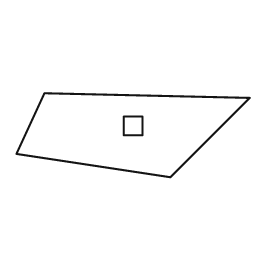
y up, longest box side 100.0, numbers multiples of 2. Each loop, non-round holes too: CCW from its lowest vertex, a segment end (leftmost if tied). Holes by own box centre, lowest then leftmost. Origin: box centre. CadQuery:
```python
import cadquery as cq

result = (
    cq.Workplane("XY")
    .moveTo(16.0, -18.0)
    .lineTo(50.0, 16.0)
    .lineTo(-38.0, 18.0)
    .lineTo(-50.0, -8.0)
    .close()
    .moveTo(-4.0, 0.0)
    .lineTo(4.0, 0.0)
    .lineTo(4.0, 8.0)
    .lineTo(-4.0, 8.0)
    .close()
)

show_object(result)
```